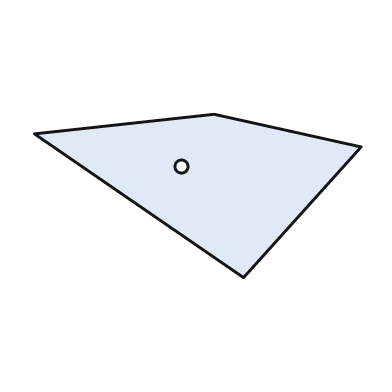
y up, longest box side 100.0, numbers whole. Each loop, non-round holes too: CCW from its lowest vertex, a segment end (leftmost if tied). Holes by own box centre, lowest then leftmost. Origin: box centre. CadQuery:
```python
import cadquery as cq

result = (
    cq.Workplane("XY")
    .moveTo(14.0, -25.0)
    .lineTo(50.0, 15.0)
    .lineTo(5.0, 25.0)
    .lineTo(-50.0, 19.0)
    .close()
    .moveTo(-5.0, 9.0)
    .circle(2.0)
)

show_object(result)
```